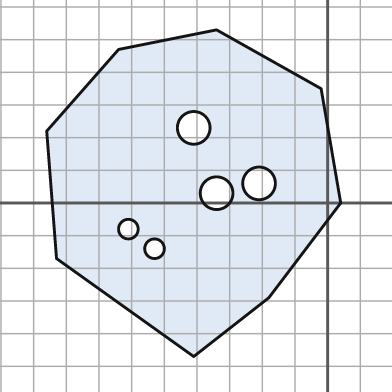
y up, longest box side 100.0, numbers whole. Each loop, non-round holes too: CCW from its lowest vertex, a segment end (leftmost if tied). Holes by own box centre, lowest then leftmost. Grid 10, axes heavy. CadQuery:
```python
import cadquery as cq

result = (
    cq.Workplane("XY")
    .moveTo(-41.0, -47.0)
    .lineTo(-18.0, -29.0)
    .lineTo(4.0, 0.0)
    .lineTo(-2.0, 35.0)
    .lineTo(-34.0, 53.0)
    .lineTo(-64.0, 47.0)
    .lineTo(-86.0, 22.0)
    .lineTo(-83.0, -17.0)
    .close()
    .moveTo(-53.0, -14.0)
    .circle(3.0)
    .moveTo(-61.0, -8.0)
    .circle(3.0)
    .moveTo(-34.0, 3.0)
    .circle(5.0)
    .moveTo(-21.0, 6.0)
    .circle(5.0)
    .moveTo(-41.0, 23.0)
    .circle(5.0)
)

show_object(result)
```